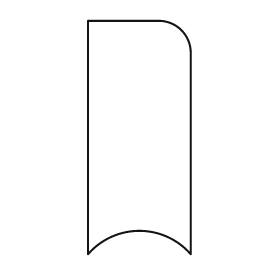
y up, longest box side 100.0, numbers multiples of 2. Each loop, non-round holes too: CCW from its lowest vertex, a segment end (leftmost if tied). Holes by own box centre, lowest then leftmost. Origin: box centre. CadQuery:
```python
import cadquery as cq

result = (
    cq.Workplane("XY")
    .moveTo(-22.0, -50.0)
    .threePointArc((0.0, -40.0), (22.0, -50.0))
    .lineTo(22.0, 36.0)
    .threePointArc((18.0, 46.0), (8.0, 50.0))
    .lineTo(-22.0, 50.0)
    .close()
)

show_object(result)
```